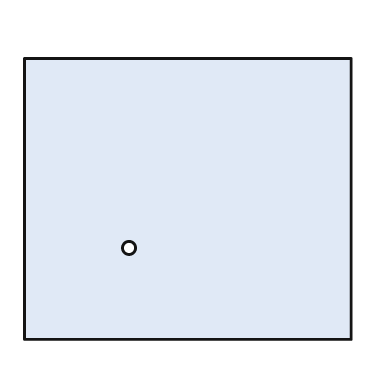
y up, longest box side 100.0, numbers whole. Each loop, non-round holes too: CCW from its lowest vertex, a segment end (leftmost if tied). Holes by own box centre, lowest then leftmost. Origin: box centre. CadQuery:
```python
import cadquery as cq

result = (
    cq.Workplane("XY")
    .moveTo(-50.0, -43.0)
    .lineTo(50.0, -43.0)
    .lineTo(50.0, 43.0)
    .lineTo(-50.0, 43.0)
    .close()
    .moveTo(-18.0, -15.0)
    .circle(2.0)
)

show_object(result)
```